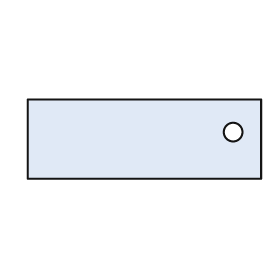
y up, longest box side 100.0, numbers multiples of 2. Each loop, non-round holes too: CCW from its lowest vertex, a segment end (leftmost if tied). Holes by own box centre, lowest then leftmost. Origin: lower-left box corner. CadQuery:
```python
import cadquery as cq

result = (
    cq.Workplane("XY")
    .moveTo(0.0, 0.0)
    .lineTo(100.0, 0.0)
    .lineTo(100.0, 34.0)
    .lineTo(0.0, 34.0)
    .close()
    .moveTo(88.0, 20.0)
    .circle(4.0)
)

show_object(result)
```